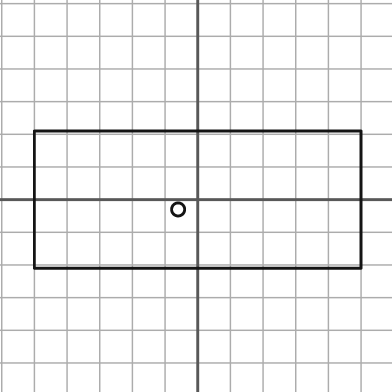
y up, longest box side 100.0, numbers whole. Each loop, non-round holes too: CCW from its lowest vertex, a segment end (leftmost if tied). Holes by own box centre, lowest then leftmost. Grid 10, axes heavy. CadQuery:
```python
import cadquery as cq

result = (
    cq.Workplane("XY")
    .moveTo(-50.0, -21.0)
    .lineTo(50.0, -21.0)
    .lineTo(50.0, 21.0)
    .lineTo(-50.0, 21.0)
    .close()
    .moveTo(-6.0, -3.0)
    .circle(2.0)
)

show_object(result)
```